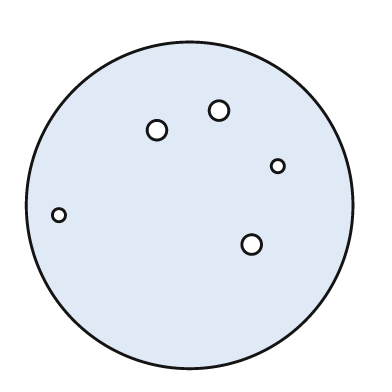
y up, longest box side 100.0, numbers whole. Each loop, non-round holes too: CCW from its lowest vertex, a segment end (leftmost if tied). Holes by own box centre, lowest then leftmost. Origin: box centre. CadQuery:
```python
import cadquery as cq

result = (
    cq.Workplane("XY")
    .moveTo(0.0, 0.0)
    .circle(50.0)
    .moveTo(19.0, -12.0)
    .circle(3.0)
    .moveTo(-40.0, -3.0)
    .circle(2.0)
    .moveTo(27.0, 12.0)
    .circle(2.0)
    .moveTo(-10.0, 23.0)
    .circle(3.0)
    .moveTo(9.0, 29.0)
    .circle(3.0)
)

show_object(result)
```